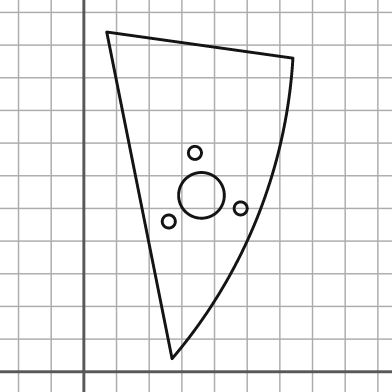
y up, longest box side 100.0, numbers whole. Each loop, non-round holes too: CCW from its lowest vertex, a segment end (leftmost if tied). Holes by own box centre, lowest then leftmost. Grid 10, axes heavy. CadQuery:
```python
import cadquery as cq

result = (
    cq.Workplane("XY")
    .moveTo(27.0, 4.0)
    .threePointArc((53.0, 47.0), (64.0, 96.0))
    .lineTo(7.0, 104.0)
    .close()
    .moveTo(26.0, 46.0)
    .circle(2.0)
    .moveTo(48.0, 50.0)
    .circle(2.0)
    .moveTo(36.0, 54.0)
    .circle(7.0)
    .moveTo(34.0, 67.0)
    .circle(2.0)
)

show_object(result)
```